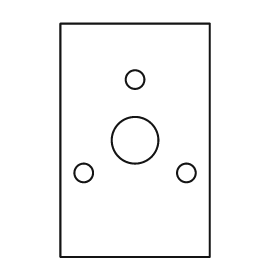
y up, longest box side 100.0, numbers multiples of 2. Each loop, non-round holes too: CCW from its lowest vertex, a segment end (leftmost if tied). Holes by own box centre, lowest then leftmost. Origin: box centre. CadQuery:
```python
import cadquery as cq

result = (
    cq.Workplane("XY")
    .moveTo(-32.0, -50.0)
    .lineTo(32.0, -50.0)
    .lineTo(32.0, 50.0)
    .lineTo(-32.0, 50.0)
    .close()
    .moveTo(-22.0, -14.0)
    .circle(4.0)
    .moveTo(22.0, -14.0)
    .circle(4.0)
    .moveTo(0.0, 0.0)
    .circle(10.0)
    .moveTo(0.0, 26.0)
    .circle(4.0)
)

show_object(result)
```